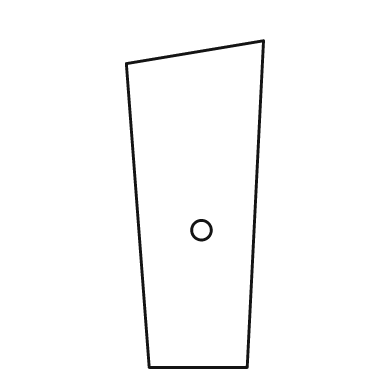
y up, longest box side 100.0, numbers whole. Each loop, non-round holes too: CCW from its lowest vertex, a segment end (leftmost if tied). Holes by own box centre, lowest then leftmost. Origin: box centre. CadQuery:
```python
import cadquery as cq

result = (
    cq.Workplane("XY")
    .moveTo(-14.0, -50.0)
    .lineTo(16.0, -50.0)
    .lineTo(21.0, 50.0)
    .lineTo(-21.0, 43.0)
    .close()
    .moveTo(2.0, -8.0)
    .circle(3.0)
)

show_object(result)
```